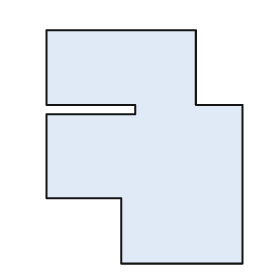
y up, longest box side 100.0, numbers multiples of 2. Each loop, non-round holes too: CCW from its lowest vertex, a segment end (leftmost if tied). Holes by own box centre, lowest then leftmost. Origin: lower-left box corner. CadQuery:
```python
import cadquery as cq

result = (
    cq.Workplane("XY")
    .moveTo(32.0, 0.0)
    .lineTo(84.0, 0.0)
    .lineTo(84.0, 68.0)
    .lineTo(64.0, 68.0)
    .lineTo(64.0, 100.0)
    .lineTo(0.0, 100.0)
    .lineTo(0.0, 68.0)
    .lineTo(38.0, 68.0)
    .lineTo(38.0, 64.0)
    .lineTo(0.0, 64.0)
    .lineTo(0.0, 28.0)
    .lineTo(32.0, 28.0)
    .close()
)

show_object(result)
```